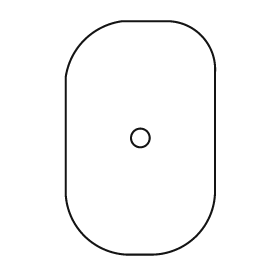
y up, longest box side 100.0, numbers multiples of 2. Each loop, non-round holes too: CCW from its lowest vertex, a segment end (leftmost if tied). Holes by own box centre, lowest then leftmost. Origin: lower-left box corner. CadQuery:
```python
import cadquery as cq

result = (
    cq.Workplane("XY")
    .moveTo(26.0, 0.0)
    .lineTo(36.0, 0.0)
    .threePointArc((56.0, 8.0), (64.0, 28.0))
    .lineTo(64.0, 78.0)
    .threePointArc((58.0, 94.0), (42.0, 100.0))
    .lineTo(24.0, 100.0)
    .threePointArc((8.0, 92.0), (0.0, 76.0))
    .lineTo(0.0, 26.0)
    .threePointArc((8.0, 8.0), (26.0, 0.0))
    .close()
    .moveTo(32.0, 50.0)
    .circle(4.0)
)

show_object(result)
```